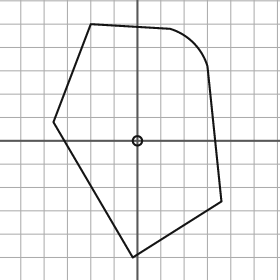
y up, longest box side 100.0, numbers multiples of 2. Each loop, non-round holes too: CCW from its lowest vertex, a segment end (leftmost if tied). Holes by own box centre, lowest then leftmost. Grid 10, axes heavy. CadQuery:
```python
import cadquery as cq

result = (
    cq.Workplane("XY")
    .moveTo(-2.0, -50.0)
    .lineTo(36.0, -26.0)
    .lineTo(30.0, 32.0)
    .threePointArc((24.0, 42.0), (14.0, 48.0))
    .lineTo(-20.0, 50.0)
    .lineTo(-36.0, 8.0)
    .close()
    .moveTo(0.0, 0.0)
    .circle(2.0)
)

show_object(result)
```